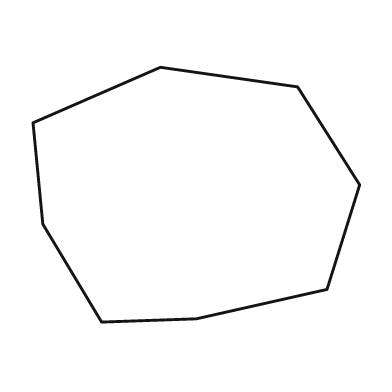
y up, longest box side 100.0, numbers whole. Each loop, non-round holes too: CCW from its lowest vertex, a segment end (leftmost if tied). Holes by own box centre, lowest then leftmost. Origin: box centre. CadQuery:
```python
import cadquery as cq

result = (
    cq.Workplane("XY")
    .moveTo(-29.0, -39.0)
    .lineTo(0.0, -38.0)
    .lineTo(40.0, -29.0)
    .lineTo(50.0, 3.0)
    .lineTo(31.0, 33.0)
    .lineTo(-11.0, 39.0)
    .lineTo(-50.0, 22.0)
    .lineTo(-47.0, -9.0)
    .close()
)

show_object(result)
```